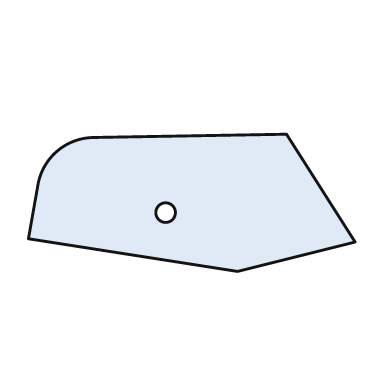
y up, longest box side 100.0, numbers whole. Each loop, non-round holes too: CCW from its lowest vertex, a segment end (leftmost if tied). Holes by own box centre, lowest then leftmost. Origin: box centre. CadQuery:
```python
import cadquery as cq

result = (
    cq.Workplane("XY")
    .moveTo(14.0, -21.0)
    .lineTo(50.0, -12.0)
    .lineTo(29.0, 21.0)
    .lineTo(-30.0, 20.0)
    .threePointArc((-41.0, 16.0), (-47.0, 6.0))
    .lineTo(-50.0, -11.0)
    .close()
    .moveTo(-8.0, -3.0)
    .circle(3.0)
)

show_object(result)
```